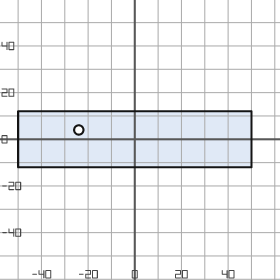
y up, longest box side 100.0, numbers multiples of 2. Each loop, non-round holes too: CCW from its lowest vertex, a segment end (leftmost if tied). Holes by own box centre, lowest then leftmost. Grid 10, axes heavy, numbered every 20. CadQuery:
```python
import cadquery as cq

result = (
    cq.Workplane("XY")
    .moveTo(-50.0, -12.0)
    .lineTo(50.0, -12.0)
    .lineTo(50.0, 12.0)
    .lineTo(-50.0, 12.0)
    .close()
    .moveTo(-24.0, 4.0)
    .circle(2.0)
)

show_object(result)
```